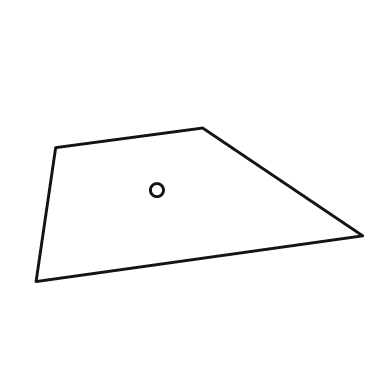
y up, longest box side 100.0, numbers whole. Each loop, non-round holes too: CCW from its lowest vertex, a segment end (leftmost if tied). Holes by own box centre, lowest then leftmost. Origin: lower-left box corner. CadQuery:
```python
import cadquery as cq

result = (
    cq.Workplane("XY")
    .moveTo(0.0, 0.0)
    .lineTo(100.0, 14.0)
    .lineTo(51.0, 47.0)
    .lineTo(6.0, 41.0)
    .close()
    .moveTo(37.0, 28.0)
    .circle(2.0)
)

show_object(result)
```